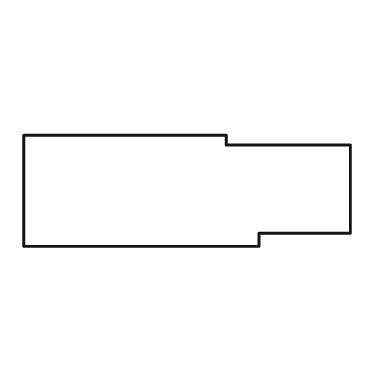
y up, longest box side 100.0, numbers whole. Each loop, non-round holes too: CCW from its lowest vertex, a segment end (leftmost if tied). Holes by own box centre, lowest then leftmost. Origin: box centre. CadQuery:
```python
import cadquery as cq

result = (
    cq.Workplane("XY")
    .moveTo(-50.0, -17.0)
    .lineTo(22.0, -17.0)
    .lineTo(22.0, -13.0)
    .lineTo(50.0, -13.0)
    .lineTo(50.0, 14.0)
    .lineTo(12.0, 14.0)
    .lineTo(12.0, 17.0)
    .lineTo(-50.0, 17.0)
    .close()
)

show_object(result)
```